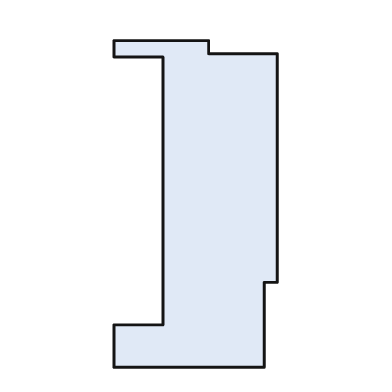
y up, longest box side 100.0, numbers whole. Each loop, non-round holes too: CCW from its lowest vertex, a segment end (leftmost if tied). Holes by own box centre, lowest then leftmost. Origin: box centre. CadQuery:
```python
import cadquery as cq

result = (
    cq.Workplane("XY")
    .moveTo(-25.0, -50.0)
    .lineTo(21.0, -50.0)
    .lineTo(21.0, -24.0)
    .lineTo(25.0, -24.0)
    .lineTo(25.0, 46.0)
    .lineTo(4.0, 46.0)
    .lineTo(4.0, 50.0)
    .lineTo(-25.0, 50.0)
    .lineTo(-25.0, 45.0)
    .lineTo(-10.0, 45.0)
    .lineTo(-10.0, -37.0)
    .lineTo(-25.0, -37.0)
    .close()
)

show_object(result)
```